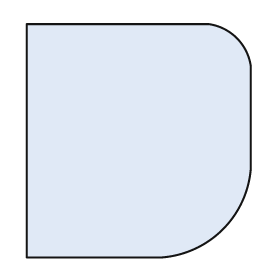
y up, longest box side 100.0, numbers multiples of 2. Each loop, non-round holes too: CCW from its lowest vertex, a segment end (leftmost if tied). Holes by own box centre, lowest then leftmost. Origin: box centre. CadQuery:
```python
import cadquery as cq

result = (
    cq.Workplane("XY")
    .moveTo(-48.0, -50.0)
    .lineTo(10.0, -50.0)
    .threePointArc((36.0, -38.0), (48.0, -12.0))
    .lineTo(48.0, 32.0)
    .threePointArc((42.0, 44.0), (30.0, 50.0))
    .lineTo(-48.0, 50.0)
    .close()
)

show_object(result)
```